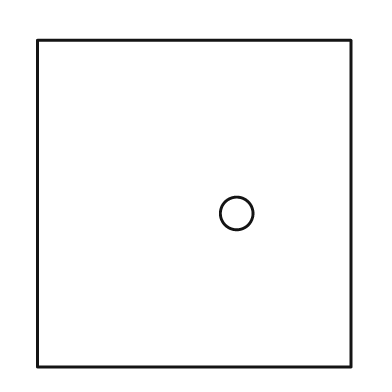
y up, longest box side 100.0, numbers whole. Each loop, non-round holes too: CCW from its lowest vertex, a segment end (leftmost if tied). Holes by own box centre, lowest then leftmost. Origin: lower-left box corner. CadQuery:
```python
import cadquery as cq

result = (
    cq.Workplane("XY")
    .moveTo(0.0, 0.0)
    .lineTo(96.0, 0.0)
    .lineTo(96.0, 100.0)
    .lineTo(0.0, 100.0)
    .close()
    .moveTo(61.0, 47.0)
    .circle(5.0)
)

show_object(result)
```